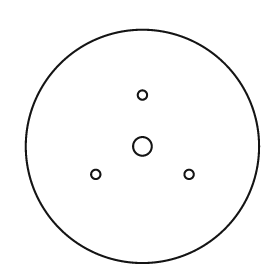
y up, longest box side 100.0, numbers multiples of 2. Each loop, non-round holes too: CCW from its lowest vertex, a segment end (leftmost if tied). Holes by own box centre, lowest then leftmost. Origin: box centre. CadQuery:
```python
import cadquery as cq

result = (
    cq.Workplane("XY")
    .moveTo(0.0, 0.0)
    .circle(50.0)
    .moveTo(-20.0, -12.0)
    .circle(2.0)
    .moveTo(20.0, -12.0)
    .circle(2.0)
    .moveTo(0.0, 0.0)
    .circle(4.0)
    .moveTo(0.0, 22.0)
    .circle(2.0)
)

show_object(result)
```